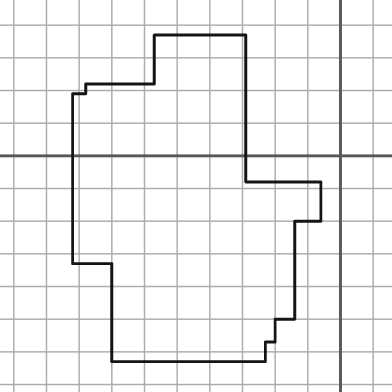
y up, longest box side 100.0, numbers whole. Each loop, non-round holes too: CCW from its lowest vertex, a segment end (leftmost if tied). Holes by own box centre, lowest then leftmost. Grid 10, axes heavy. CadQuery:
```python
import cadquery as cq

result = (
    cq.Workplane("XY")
    .moveTo(-70.0, -63.0)
    .lineTo(-23.0, -63.0)
    .lineTo(-23.0, -57.0)
    .lineTo(-20.0, -57.0)
    .lineTo(-20.0, -50.0)
    .lineTo(-14.0, -50.0)
    .lineTo(-14.0, -20.0)
    .lineTo(-6.0, -20.0)
    .lineTo(-6.0, -8.0)
    .lineTo(-29.0, -8.0)
    .lineTo(-29.0, 37.0)
    .lineTo(-57.0, 37.0)
    .lineTo(-57.0, 22.0)
    .lineTo(-78.0, 22.0)
    .lineTo(-78.0, 19.0)
    .lineTo(-82.0, 19.0)
    .lineTo(-82.0, -33.0)
    .lineTo(-70.0, -33.0)
    .close()
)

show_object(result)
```